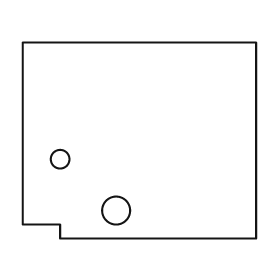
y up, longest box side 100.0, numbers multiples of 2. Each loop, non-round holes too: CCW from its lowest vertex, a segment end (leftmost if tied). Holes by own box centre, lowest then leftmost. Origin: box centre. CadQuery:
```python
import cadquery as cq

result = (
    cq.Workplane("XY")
    .moveTo(-34.0, -42.0)
    .lineTo(50.0, -42.0)
    .lineTo(50.0, 42.0)
    .lineTo(-50.0, 42.0)
    .lineTo(-50.0, -36.0)
    .lineTo(-34.0, -36.0)
    .close()
    .moveTo(-10.0, -30.0)
    .circle(6.0)
    .moveTo(-34.0, -8.0)
    .circle(4.0)
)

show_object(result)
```